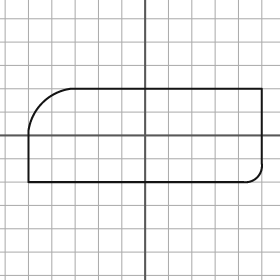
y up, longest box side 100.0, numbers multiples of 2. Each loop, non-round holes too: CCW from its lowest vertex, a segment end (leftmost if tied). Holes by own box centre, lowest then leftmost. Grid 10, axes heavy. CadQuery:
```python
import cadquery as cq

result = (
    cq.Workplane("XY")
    .moveTo(-50.0, -20.0)
    .lineTo(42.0, -20.0)
    .threePointArc((48.0, -18.0), (50.0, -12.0))
    .lineTo(50.0, 20.0)
    .lineTo(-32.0, 20.0)
    .threePointArc((-44.0, 14.0), (-50.0, 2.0))
    .close()
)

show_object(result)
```